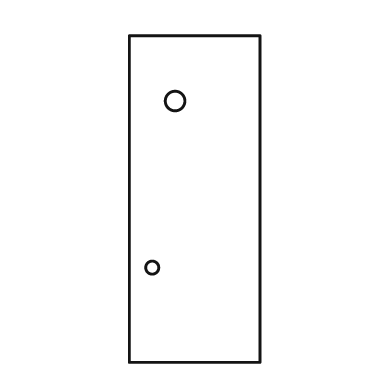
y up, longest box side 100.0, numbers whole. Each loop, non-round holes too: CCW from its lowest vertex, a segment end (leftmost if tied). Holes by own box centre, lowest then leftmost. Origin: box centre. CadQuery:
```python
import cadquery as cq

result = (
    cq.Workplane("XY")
    .moveTo(-20.0, -50.0)
    .lineTo(20.0, -50.0)
    .lineTo(20.0, 50.0)
    .lineTo(-20.0, 50.0)
    .close()
    .moveTo(-13.0, -21.0)
    .circle(2.0)
    .moveTo(-6.0, 30.0)
    .circle(3.0)
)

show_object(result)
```